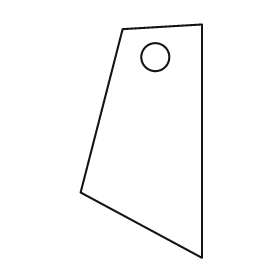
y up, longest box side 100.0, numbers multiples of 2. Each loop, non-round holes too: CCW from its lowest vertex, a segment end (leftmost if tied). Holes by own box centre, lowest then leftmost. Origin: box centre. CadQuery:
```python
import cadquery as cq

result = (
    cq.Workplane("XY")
    .moveTo(26.0, -50.0)
    .lineTo(26.0, 50.0)
    .lineTo(-8.0, 48.0)
    .lineTo(-26.0, -22.0)
    .close()
    .moveTo(6.0, 36.0)
    .circle(6.0)
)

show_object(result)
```